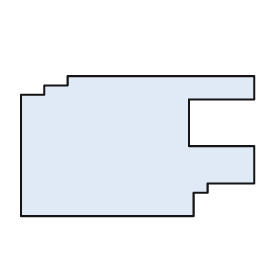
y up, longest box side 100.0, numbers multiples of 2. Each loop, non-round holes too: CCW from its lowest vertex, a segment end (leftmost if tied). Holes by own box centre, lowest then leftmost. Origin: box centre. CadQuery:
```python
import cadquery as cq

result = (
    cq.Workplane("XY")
    .moveTo(-50.0, -30.0)
    .lineTo(24.0, -30.0)
    .lineTo(24.0, -20.0)
    .lineTo(30.0, -20.0)
    .lineTo(30.0, -16.0)
    .lineTo(50.0, -16.0)
    .lineTo(50.0, 0.0)
    .lineTo(22.0, 0.0)
    .lineTo(22.0, 20.0)
    .lineTo(50.0, 20.0)
    .lineTo(50.0, 30.0)
    .lineTo(-30.0, 30.0)
    .lineTo(-30.0, 26.0)
    .lineTo(-40.0, 26.0)
    .lineTo(-40.0, 22.0)
    .lineTo(-50.0, 22.0)
    .close()
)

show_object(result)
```